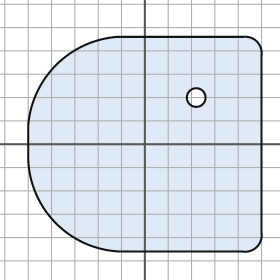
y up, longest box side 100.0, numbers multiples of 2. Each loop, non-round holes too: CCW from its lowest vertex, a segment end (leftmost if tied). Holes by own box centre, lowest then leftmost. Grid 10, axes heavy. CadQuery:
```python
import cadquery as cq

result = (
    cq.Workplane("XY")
    .moveTo(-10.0, -46.0)
    .lineTo(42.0, -46.0)
    .threePointArc((48.0, -44.0), (50.0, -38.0))
    .lineTo(50.0, 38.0)
    .threePointArc((48.0, 44.0), (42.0, 46.0))
    .lineTo(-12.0, 46.0)
    .threePointArc((-38.0, 34.0), (-50.0, 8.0))
    .lineTo(-50.0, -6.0)
    .threePointArc((-38.0, -34.0), (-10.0, -46.0))
    .close()
    .moveTo(22.0, 20.0)
    .circle(4.0)
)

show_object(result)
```